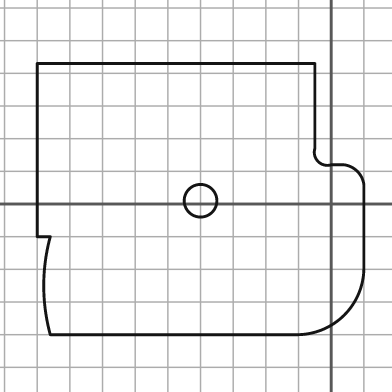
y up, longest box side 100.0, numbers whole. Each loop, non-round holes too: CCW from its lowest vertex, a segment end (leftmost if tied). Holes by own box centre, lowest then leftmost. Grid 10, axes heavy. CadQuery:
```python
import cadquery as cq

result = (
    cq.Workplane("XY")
    .moveTo(-86.0, -40.0)
    .lineTo(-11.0, -40.0)
    .threePointArc((4.0, -34.0), (10.0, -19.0))
    .lineTo(10.0, 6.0)
    .threePointArc((8.0, 10.0), (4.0, 12.0))
    .lineTo(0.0, 12.0)
    .threePointArc((-4.0, 13.0), (-5.0, 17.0))
    .lineTo(-5.0, 43.0)
    .lineTo(-90.0, 43.0)
    .lineTo(-90.0, -10.0)
    .lineTo(-86.0, -10.0)
    .threePointArc((-88.0, -25.0), (-86.0, -40.0))
    .close()
    .moveTo(-40.0, 1.0)
    .circle(5.0)
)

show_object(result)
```